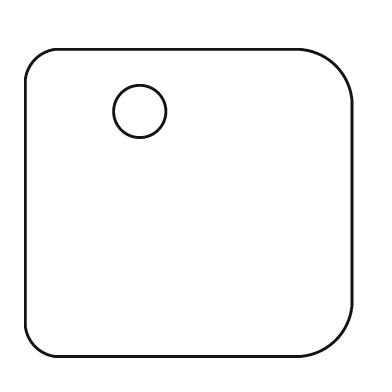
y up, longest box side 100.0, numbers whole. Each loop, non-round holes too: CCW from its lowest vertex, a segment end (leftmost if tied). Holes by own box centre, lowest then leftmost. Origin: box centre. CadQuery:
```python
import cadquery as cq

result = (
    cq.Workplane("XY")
    .moveTo(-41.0, -47.0)
    .lineTo(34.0, -47.0)
    .threePointArc((45.0, -42.0), (50.0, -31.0))
    .lineTo(50.0, 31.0)
    .threePointArc((45.0, 42.0), (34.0, 47.0))
    .lineTo(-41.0, 47.0)
    .threePointArc((-47.0, 44.0), (-50.0, 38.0))
    .lineTo(-50.0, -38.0)
    .threePointArc((-47.0, -44.0), (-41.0, -47.0))
    .close()
    .moveTo(-15.0, 28.0)
    .circle(8.0)
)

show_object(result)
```